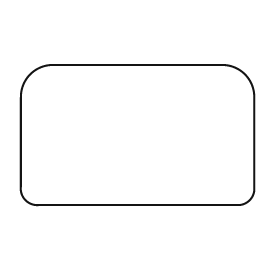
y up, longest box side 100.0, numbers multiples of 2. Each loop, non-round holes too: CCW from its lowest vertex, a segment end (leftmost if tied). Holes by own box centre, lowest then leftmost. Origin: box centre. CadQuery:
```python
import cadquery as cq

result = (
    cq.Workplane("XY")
    .moveTo(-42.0, -30.0)
    .lineTo(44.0, -30.0)
    .threePointArc((48.0, -28.0), (50.0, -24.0))
    .lineTo(50.0, 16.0)
    .threePointArc((46.0, 26.0), (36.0, 30.0))
    .lineTo(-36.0, 30.0)
    .threePointArc((-46.0, 26.0), (-50.0, 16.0))
    .lineTo(-50.0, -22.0)
    .threePointArc((-48.0, -28.0), (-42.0, -30.0))
    .close()
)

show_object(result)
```